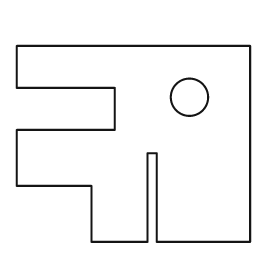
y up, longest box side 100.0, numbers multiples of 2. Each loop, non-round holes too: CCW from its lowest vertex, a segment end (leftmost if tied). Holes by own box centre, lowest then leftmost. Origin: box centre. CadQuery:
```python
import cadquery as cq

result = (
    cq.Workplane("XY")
    .moveTo(-18.0, -42.0)
    .lineTo(6.0, -42.0)
    .lineTo(6.0, -4.0)
    .lineTo(10.0, -4.0)
    .lineTo(10.0, -42.0)
    .lineTo(50.0, -42.0)
    .lineTo(50.0, 42.0)
    .lineTo(-50.0, 42.0)
    .lineTo(-50.0, 24.0)
    .lineTo(-8.0, 24.0)
    .lineTo(-8.0, 6.0)
    .lineTo(-50.0, 6.0)
    .lineTo(-50.0, -18.0)
    .lineTo(-18.0, -18.0)
    .close()
    .moveTo(24.0, 20.0)
    .circle(8.0)
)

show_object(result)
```